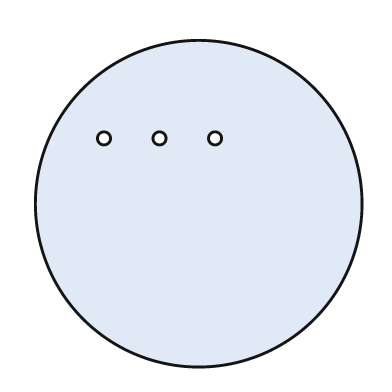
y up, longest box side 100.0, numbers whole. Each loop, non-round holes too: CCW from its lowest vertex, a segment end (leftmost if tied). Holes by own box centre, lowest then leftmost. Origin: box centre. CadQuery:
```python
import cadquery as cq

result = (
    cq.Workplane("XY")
    .moveTo(0.0, 0.0)
    .circle(50.0)
    .moveTo(-29.0, 20.0)
    .circle(2.0)
    .moveTo(-12.0, 20.0)
    .circle(2.0)
    .moveTo(5.0, 20.0)
    .circle(2.0)
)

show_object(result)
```